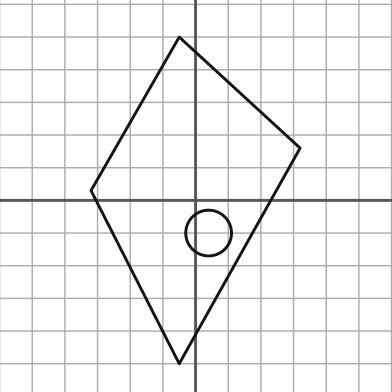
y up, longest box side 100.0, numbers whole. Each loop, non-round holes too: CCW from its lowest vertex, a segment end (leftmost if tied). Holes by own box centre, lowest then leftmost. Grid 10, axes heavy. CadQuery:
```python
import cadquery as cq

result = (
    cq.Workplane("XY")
    .moveTo(-5.0, -50.0)
    .lineTo(32.0, 16.0)
    .lineTo(-5.0, 50.0)
    .lineTo(-32.0, 3.0)
    .close()
    .moveTo(4.0, -10.0)
    .circle(7.0)
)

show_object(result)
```